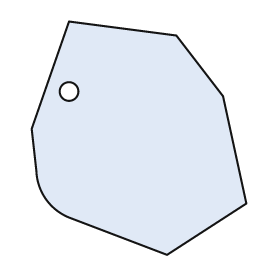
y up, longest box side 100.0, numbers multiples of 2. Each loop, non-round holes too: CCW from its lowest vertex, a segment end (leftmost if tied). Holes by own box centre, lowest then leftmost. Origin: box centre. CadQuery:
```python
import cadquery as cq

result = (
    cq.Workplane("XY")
    .moveTo(12.0, -50.0)
    .lineTo(46.0, -28.0)
    .lineTo(36.0, 18.0)
    .lineTo(16.0, 44.0)
    .lineTo(-30.0, 50.0)
    .lineTo(-46.0, 4.0)
    .lineTo(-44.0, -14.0)
    .threePointArc((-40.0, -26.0), (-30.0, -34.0))
    .close()
    .moveTo(-30.0, 20.0)
    .circle(4.0)
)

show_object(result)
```